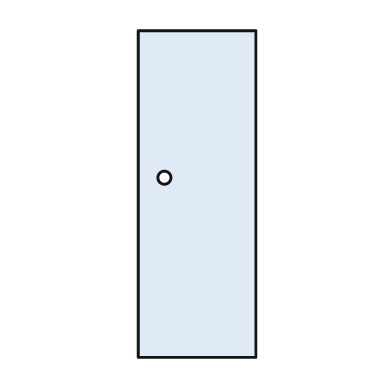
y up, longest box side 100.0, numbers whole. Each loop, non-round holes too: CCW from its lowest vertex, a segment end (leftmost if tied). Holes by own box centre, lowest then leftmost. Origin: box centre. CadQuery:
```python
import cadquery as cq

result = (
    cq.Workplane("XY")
    .moveTo(-18.0, -50.0)
    .lineTo(18.0, -50.0)
    .lineTo(18.0, 50.0)
    .lineTo(-18.0, 50.0)
    .close()
    .moveTo(-10.0, 5.0)
    .circle(2.0)
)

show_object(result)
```